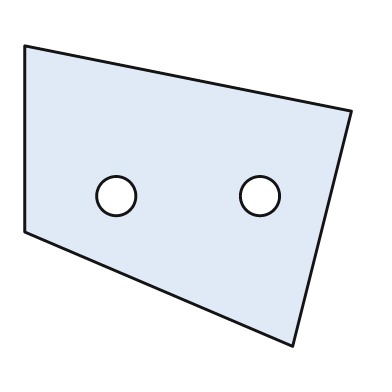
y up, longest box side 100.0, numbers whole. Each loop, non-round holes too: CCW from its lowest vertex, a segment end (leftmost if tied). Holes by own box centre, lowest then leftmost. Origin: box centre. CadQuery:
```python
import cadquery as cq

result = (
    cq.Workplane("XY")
    .moveTo(32.0, -46.0)
    .lineTo(50.0, 26.0)
    .lineTo(-50.0, 46.0)
    .lineTo(-50.0, -11.0)
    .close()
    .moveTo(-22.0, 0.0)
    .circle(6.0)
    .moveTo(22.0, 0.0)
    .circle(6.0)
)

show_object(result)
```